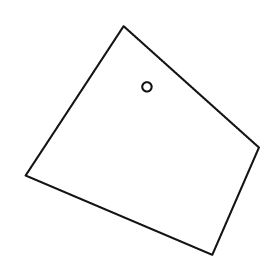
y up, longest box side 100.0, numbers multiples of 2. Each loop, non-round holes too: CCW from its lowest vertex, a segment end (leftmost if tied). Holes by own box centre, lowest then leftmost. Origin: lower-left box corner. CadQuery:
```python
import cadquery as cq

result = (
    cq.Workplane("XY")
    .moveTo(80.0, 0.0)
    .lineTo(100.0, 46.0)
    .lineTo(42.0, 98.0)
    .lineTo(0.0, 34.0)
    .close()
    .moveTo(52.0, 72.0)
    .circle(2.0)
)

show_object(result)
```